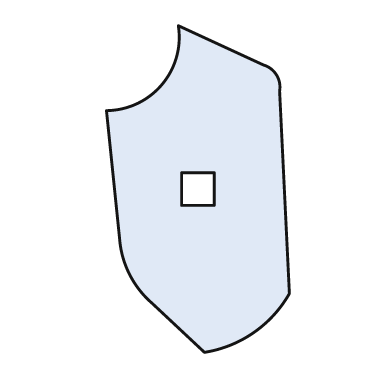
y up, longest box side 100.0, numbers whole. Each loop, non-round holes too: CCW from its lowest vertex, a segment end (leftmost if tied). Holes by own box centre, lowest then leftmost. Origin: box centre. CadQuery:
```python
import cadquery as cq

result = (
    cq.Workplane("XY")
    .moveTo(2.0, -50.0)
    .threePointArc((17.0, -44.0), (28.0, -32.0))
    .lineTo(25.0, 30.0)
    .threePointArc((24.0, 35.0), (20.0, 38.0))
    .lineTo(-6.0, 50.0)
    .threePointArc((-11.0, 32.0), (-28.0, 24.0))
    .lineTo(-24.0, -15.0)
    .threePointArc((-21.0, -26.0), (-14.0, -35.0))
    .close()
    .moveTo(-5.0, -5.0)
    .lineTo(5.0, -5.0)
    .lineTo(5.0, 5.0)
    .lineTo(-5.0, 5.0)
    .close()
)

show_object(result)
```